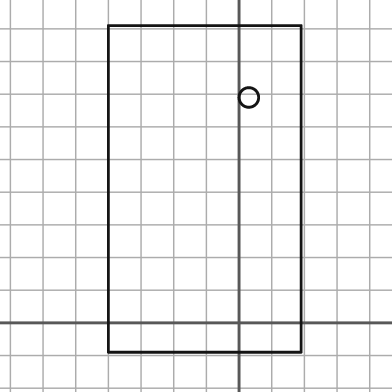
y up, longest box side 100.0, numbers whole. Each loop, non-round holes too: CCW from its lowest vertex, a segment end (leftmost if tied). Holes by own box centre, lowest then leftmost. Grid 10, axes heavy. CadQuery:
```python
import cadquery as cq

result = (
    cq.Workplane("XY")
    .moveTo(-40.0, -9.0)
    .lineTo(19.0, -9.0)
    .lineTo(19.0, 91.0)
    .lineTo(-40.0, 91.0)
    .close()
    .moveTo(3.0, 69.0)
    .circle(3.0)
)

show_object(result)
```